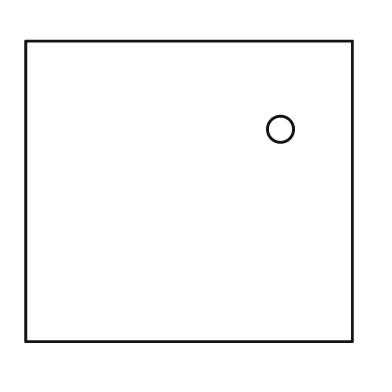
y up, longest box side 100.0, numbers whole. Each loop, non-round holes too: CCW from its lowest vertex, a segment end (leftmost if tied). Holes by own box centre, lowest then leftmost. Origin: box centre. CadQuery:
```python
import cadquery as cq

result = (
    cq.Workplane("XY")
    .moveTo(-50.0, -46.0)
    .lineTo(50.0, -46.0)
    .lineTo(50.0, 46.0)
    .lineTo(-50.0, 46.0)
    .close()
    .moveTo(28.0, 19.0)
    .circle(4.0)
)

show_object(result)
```